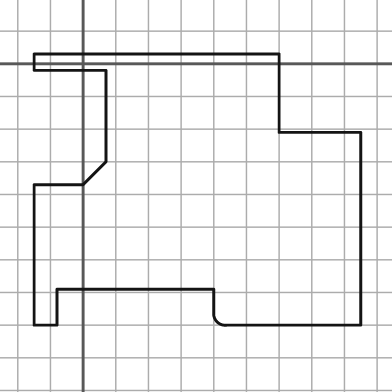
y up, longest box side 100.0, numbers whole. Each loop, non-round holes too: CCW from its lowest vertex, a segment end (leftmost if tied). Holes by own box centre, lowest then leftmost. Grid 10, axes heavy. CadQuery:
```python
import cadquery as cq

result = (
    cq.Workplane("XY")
    .moveTo(-15.0, -80.0)
    .lineTo(-8.0, -80.0)
    .lineTo(-8.0, -69.0)
    .lineTo(40.0, -69.0)
    .lineTo(40.0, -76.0)
    .threePointArc((41.0, -79.0), (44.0, -80.0))
    .lineTo(85.0, -80.0)
    .lineTo(85.0, -21.0)
    .lineTo(60.0, -21.0)
    .lineTo(60.0, 3.0)
    .lineTo(-15.0, 3.0)
    .lineTo(-15.0, -2.0)
    .lineTo(7.0, -2.0)
    .lineTo(7.0, -30.0)
    .lineTo(0.0, -37.0)
    .lineTo(-15.0, -37.0)
    .close()
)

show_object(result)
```